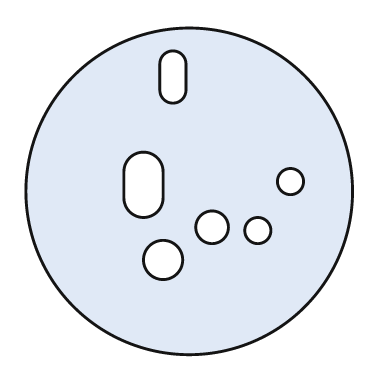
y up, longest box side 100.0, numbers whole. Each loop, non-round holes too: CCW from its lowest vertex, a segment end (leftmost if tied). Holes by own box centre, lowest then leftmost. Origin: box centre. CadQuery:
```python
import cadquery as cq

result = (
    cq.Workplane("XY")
    .moveTo(0.0, 0.0)
    .circle(50.0)
    .moveTo(-8.0, -21.0)
    .circle(6.0)
    .moveTo(21.0, -12.0)
    .circle(4.0)
    .moveTo(7.0, -11.0)
    .circle(5.0)
    .moveTo(-20.0, -2.0)
    .threePointArc((-14.0, -8.0), (-8.0, -2.0))
    .lineTo(-8.0, 6.0)
    .threePointArc((-14.0, 12.0), (-20.0, 6.0))
    .close()
    .moveTo(31.0, 3.0)
    .circle(4.0)
    .moveTo(-9.0, 31.0)
    .threePointArc((-5.0, 27.0), (-1.0, 31.0))
    .lineTo(-1.0, 39.0)
    .threePointArc((-5.0, 43.0), (-9.0, 39.0))
    .close()
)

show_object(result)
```